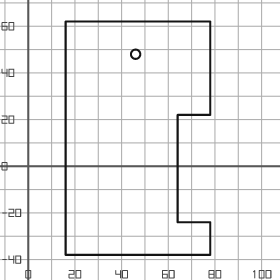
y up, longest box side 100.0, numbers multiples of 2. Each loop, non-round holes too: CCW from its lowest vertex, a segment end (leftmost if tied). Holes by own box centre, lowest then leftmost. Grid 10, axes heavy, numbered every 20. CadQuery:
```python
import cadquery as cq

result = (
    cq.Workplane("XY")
    .moveTo(16.0, -38.0)
    .lineTo(78.0, -38.0)
    .lineTo(78.0, -24.0)
    .lineTo(64.0, -24.0)
    .lineTo(64.0, 22.0)
    .lineTo(78.0, 22.0)
    .lineTo(78.0, 62.0)
    .lineTo(16.0, 62.0)
    .close()
    .moveTo(46.0, 48.0)
    .circle(2.0)
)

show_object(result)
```